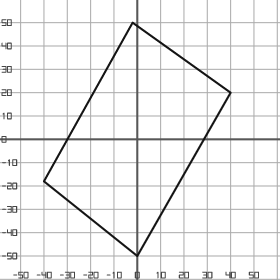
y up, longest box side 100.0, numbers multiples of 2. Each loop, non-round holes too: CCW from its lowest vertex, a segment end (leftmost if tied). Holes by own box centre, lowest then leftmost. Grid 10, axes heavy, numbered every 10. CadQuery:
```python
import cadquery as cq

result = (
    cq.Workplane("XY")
    .moveTo(0.0, -50.0)
    .lineTo(40.0, 20.0)
    .lineTo(-2.0, 50.0)
    .lineTo(-40.0, -18.0)
    .close()
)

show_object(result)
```